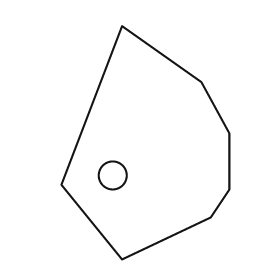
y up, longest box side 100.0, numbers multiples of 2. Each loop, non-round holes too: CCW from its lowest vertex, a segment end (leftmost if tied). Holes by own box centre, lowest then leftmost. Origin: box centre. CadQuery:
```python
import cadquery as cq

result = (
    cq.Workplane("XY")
    .moveTo(-10.0, -50.0)
    .lineTo(28.0, -32.0)
    .lineTo(36.0, -20.0)
    .lineTo(36.0, 4.0)
    .lineTo(24.0, 26.0)
    .lineTo(-10.0, 50.0)
    .lineTo(-36.0, -18.0)
    .close()
    .moveTo(-14.0, -14.0)
    .circle(6.0)
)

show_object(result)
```